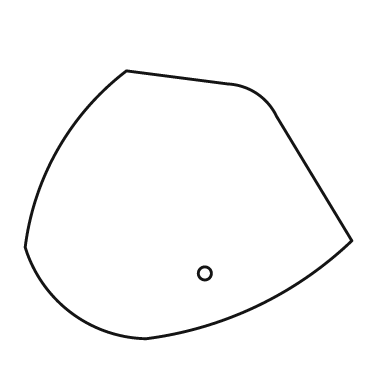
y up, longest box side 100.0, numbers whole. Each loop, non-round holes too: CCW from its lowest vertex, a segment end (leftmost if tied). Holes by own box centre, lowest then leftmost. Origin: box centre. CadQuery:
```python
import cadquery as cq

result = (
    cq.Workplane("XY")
    .moveTo(-13.0, -41.0)
    .threePointArc((21.0, -31.0), (50.0, -11.0))
    .lineTo(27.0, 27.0)
    .threePointArc((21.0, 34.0), (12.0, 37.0))
    .lineTo(-19.0, 41.0)
    .threePointArc((-40.0, 17.0), (-50.0, -13.0))
    .threePointArc((-36.0, -33.0), (-13.0, -41.0))
    .close()
    .moveTo(5.0, -21.0)
    .circle(2.0)
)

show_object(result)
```